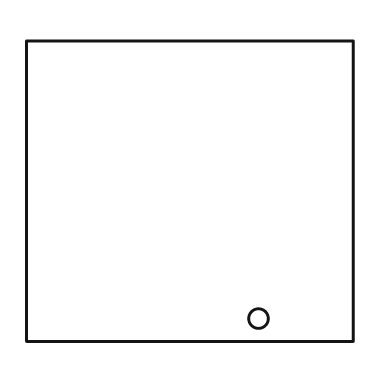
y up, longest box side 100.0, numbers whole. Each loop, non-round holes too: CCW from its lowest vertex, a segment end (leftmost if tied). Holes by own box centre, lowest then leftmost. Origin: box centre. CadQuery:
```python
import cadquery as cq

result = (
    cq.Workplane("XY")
    .moveTo(-50.0, -46.0)
    .lineTo(50.0, -46.0)
    .lineTo(50.0, 46.0)
    .lineTo(-50.0, 46.0)
    .close()
    .moveTo(21.0, -39.0)
    .circle(3.0)
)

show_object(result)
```